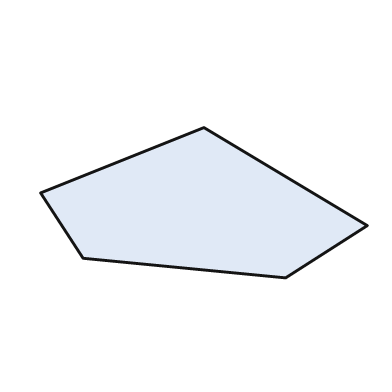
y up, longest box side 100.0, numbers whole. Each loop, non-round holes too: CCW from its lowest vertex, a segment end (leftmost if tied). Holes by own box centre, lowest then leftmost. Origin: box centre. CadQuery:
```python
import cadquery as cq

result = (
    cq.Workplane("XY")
    .moveTo(25.0, -23.0)
    .lineTo(50.0, -7.0)
    .lineTo(0.0, 23.0)
    .lineTo(-50.0, 3.0)
    .lineTo(-37.0, -17.0)
    .close()
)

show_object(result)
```